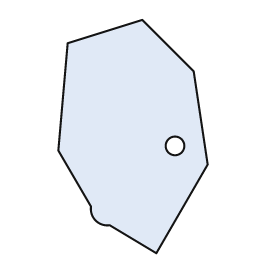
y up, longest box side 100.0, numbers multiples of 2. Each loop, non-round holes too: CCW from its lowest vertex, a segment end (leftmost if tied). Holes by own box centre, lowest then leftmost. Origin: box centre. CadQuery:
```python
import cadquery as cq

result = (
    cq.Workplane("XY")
    .moveTo(10.0, -50.0)
    .lineTo(32.0, -12.0)
    .lineTo(26.0, 28.0)
    .lineTo(4.0, 50.0)
    .lineTo(-28.0, 40.0)
    .lineTo(-32.0, -6.0)
    .lineTo(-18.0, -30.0)
    .threePointArc((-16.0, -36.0), (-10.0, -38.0))
    .close()
    .moveTo(18.0, -4.0)
    .circle(4.0)
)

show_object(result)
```